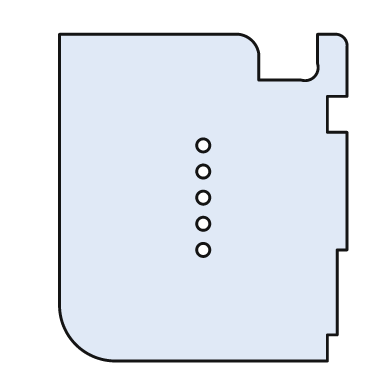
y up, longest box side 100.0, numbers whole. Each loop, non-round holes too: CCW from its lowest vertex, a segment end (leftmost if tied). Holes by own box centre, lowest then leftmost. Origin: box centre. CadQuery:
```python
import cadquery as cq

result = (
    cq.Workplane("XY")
    .moveTo(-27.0, -50.0)
    .lineTo(38.0, -50.0)
    .lineTo(38.0, -42.0)
    .lineTo(41.0, -42.0)
    .lineTo(41.0, -16.0)
    .lineTo(44.0, -16.0)
    .lineTo(44.0, 20.0)
    .lineTo(38.0, 20.0)
    .lineTo(38.0, 31.0)
    .lineTo(44.0, 31.0)
    .lineTo(44.0, 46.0)
    .threePointArc((43.0, 49.0), (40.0, 50.0))
    .lineTo(35.0, 50.0)
    .lineTo(35.0, 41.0)
    .threePointArc((34.0, 37.0), (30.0, 36.0))
    .lineTo(17.0, 36.0)
    .lineTo(17.0, 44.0)
    .threePointArc((15.0, 48.0), (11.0, 50.0))
    .lineTo(-44.0, 50.0)
    .lineTo(-44.0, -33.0)
    .threePointArc((-39.0, -45.0), (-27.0, -50.0))
    .close()
    .moveTo(0.0, -16.0)
    .circle(2.0)
    .moveTo(0.0, -8.0)
    .circle(2.0)
    .moveTo(0.0, 0.0)
    .circle(2.0)
    .moveTo(0.0, 8.0)
    .circle(2.0)
    .moveTo(0.0, 16.0)
    .circle(2.0)
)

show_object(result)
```